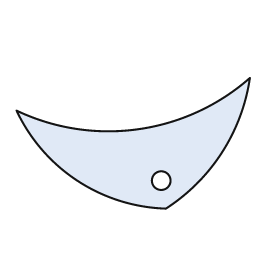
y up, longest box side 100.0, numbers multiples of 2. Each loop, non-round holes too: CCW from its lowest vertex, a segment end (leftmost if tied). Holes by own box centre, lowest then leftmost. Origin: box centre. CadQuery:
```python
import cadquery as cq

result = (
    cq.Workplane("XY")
    .moveTo(14.0, -28.0)
    .threePointArc((38.0, -4.0), (50.0, 28.0))
    .threePointArc((2.0, 6.0), (-50.0, 14.0))
    .threePointArc((-24.0, -16.0), (14.0, -28.0))
    .close()
    .moveTo(12.0, -16.0)
    .circle(4.0)
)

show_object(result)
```